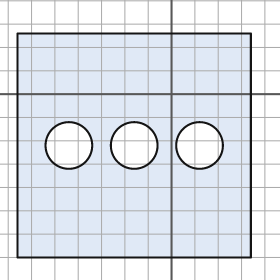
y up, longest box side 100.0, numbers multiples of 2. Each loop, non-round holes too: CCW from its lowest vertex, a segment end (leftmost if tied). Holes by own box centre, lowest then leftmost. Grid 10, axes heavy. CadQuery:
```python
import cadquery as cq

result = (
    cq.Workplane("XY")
    .moveTo(-66.0, -70.0)
    .lineTo(34.0, -70.0)
    .lineTo(34.0, 26.0)
    .lineTo(-66.0, 26.0)
    .close()
    .moveTo(-44.0, -22.0)
    .circle(10.0)
    .moveTo(-16.0, -22.0)
    .circle(10.0)
    .moveTo(12.0, -22.0)
    .circle(10.0)
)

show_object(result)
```